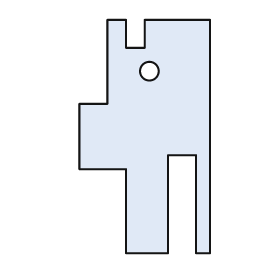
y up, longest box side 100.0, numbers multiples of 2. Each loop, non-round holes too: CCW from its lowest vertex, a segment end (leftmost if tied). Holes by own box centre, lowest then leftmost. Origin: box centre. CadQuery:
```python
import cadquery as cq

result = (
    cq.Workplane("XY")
    .moveTo(-8.0, -50.0)
    .lineTo(10.0, -50.0)
    .lineTo(10.0, -8.0)
    .lineTo(22.0, -8.0)
    .lineTo(22.0, -50.0)
    .lineTo(28.0, -50.0)
    .lineTo(28.0, 50.0)
    .lineTo(0.0, 50.0)
    .lineTo(0.0, 38.0)
    .lineTo(-8.0, 38.0)
    .lineTo(-8.0, 50.0)
    .lineTo(-16.0, 50.0)
    .lineTo(-16.0, 14.0)
    .lineTo(-28.0, 14.0)
    .lineTo(-28.0, -14.0)
    .lineTo(-8.0, -14.0)
    .close()
    .moveTo(2.0, 28.0)
    .circle(4.0)
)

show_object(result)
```